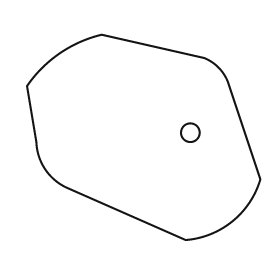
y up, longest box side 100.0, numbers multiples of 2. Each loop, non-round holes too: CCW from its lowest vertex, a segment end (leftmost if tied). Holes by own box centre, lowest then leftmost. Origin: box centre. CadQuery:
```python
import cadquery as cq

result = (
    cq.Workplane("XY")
    .moveTo(18.0, -44.0)
    .threePointArc((38.0, -36.0), (50.0, -18.0))
    .lineTo(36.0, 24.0)
    .threePointArc((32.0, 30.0), (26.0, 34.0))
    .lineTo(-18.0, 44.0)
    .threePointArc((-36.0, 36.0), (-50.0, 22.0))
    .lineTo(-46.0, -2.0)
    .threePointArc((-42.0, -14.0), (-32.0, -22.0))
    .close()
    .moveTo(20.0, 2.0)
    .circle(4.0)
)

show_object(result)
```